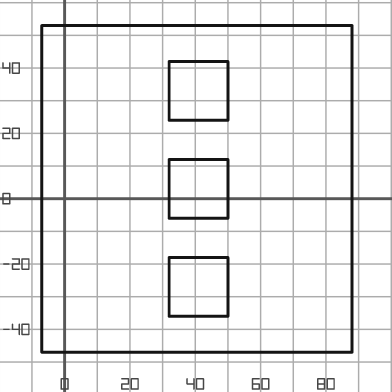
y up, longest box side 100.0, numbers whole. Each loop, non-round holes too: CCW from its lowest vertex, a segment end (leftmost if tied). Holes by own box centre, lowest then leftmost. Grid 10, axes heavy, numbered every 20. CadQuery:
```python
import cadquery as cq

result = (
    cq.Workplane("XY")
    .moveTo(-7.0, -47.0)
    .lineTo(88.0, -47.0)
    .lineTo(88.0, 53.0)
    .lineTo(-7.0, 53.0)
    .close()
    .moveTo(32.0, -36.0)
    .lineTo(50.0, -36.0)
    .lineTo(50.0, -18.0)
    .lineTo(32.0, -18.0)
    .close()
    .moveTo(32.0, -6.0)
    .lineTo(50.0, -6.0)
    .lineTo(50.0, 12.0)
    .lineTo(32.0, 12.0)
    .close()
    .moveTo(32.0, 24.0)
    .lineTo(50.0, 24.0)
    .lineTo(50.0, 42.0)
    .lineTo(32.0, 42.0)
    .close()
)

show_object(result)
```